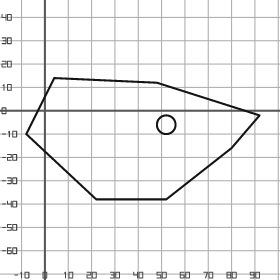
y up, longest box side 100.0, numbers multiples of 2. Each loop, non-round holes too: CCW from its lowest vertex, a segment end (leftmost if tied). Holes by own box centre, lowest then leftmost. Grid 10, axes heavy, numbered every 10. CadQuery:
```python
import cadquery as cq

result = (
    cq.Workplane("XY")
    .moveTo(22.0, -38.0)
    .lineTo(52.0, -38.0)
    .lineTo(80.0, -16.0)
    .lineTo(92.0, -2.0)
    .lineTo(48.0, 12.0)
    .lineTo(4.0, 14.0)
    .lineTo(-8.0, -10.0)
    .close()
    .moveTo(52.0, -6.0)
    .circle(4.0)
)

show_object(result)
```